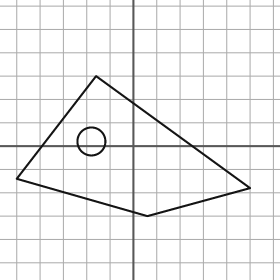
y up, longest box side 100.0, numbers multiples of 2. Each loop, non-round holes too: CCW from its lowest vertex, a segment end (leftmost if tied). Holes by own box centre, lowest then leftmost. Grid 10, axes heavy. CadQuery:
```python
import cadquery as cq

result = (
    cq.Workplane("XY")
    .moveTo(6.0, -30.0)
    .lineTo(50.0, -18.0)
    .lineTo(-16.0, 30.0)
    .lineTo(-50.0, -14.0)
    .close()
    .moveTo(-18.0, 2.0)
    .circle(6.0)
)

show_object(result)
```